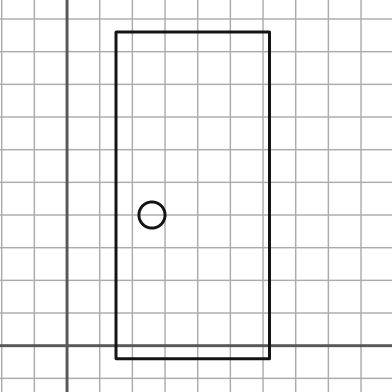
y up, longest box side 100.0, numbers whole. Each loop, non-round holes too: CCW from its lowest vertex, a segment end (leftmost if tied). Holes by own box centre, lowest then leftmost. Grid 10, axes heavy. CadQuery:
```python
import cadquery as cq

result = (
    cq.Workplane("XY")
    .moveTo(15.0, -4.0)
    .lineTo(62.0, -4.0)
    .lineTo(62.0, 96.0)
    .lineTo(15.0, 96.0)
    .close()
    .moveTo(26.0, 40.0)
    .circle(4.0)
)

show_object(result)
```